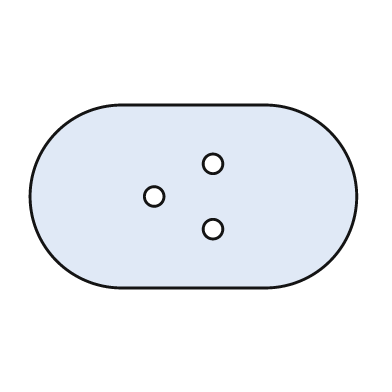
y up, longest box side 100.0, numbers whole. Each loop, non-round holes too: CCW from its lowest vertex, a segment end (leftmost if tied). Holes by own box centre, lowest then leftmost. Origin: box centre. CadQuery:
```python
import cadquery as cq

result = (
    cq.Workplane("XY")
    .moveTo(-22.0, -28.0)
    .lineTo(22.0, -28.0)
    .threePointArc((50.0, 0.0), (22.0, 28.0))
    .lineTo(-22.0, 28.0)
    .threePointArc((-50.0, 0.0), (-22.0, -28.0))
    .close()
    .moveTo(6.0, -10.0)
    .circle(3.0)
    .moveTo(-12.0, 0.0)
    .circle(3.0)
    .moveTo(6.0, 10.0)
    .circle(3.0)
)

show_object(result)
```